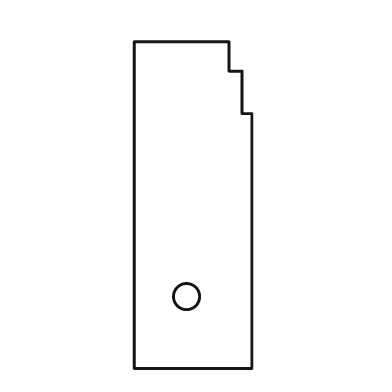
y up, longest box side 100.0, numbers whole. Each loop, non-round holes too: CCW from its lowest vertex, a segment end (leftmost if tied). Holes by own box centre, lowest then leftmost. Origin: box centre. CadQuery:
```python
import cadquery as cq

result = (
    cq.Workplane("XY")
    .moveTo(-18.0, -50.0)
    .lineTo(18.0, -50.0)
    .lineTo(18.0, 28.0)
    .lineTo(15.0, 28.0)
    .lineTo(15.0, 41.0)
    .lineTo(11.0, 41.0)
    .lineTo(11.0, 50.0)
    .lineTo(-18.0, 50.0)
    .close()
    .moveTo(-2.0, -28.0)
    .circle(4.0)
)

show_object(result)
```